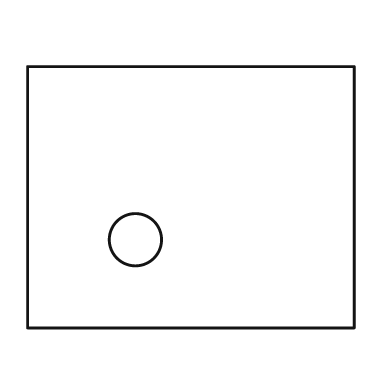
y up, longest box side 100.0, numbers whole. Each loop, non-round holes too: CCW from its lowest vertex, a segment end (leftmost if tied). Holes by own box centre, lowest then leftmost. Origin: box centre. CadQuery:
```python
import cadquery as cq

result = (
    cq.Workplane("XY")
    .moveTo(-50.0, -40.0)
    .lineTo(50.0, -40.0)
    .lineTo(50.0, 40.0)
    .lineTo(-50.0, 40.0)
    .close()
    .moveTo(-17.0, -13.0)
    .circle(8.0)
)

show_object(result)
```